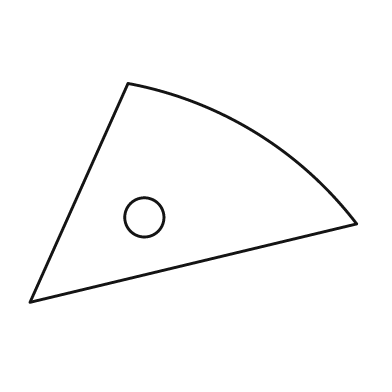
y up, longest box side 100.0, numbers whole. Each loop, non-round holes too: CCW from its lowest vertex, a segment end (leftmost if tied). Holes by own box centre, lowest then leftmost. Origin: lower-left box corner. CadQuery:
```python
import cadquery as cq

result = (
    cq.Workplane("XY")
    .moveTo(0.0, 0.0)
    .lineTo(100.0, 24.0)
    .threePointArc((69.0, 52.0), (30.0, 67.0))
    .close()
    .moveTo(35.0, 26.0)
    .circle(6.0)
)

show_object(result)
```